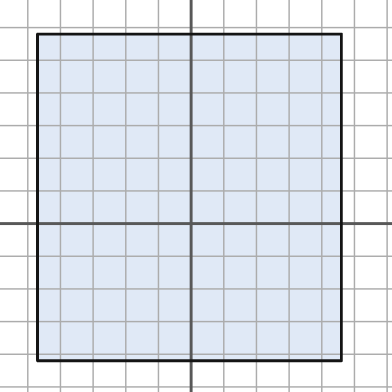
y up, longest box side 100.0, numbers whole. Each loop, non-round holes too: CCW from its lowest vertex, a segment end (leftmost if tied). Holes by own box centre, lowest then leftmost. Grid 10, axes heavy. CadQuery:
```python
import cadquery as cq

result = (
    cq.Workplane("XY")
    .moveTo(-47.0, -42.0)
    .lineTo(46.0, -42.0)
    .lineTo(46.0, 58.0)
    .lineTo(-47.0, 58.0)
    .close()
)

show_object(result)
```